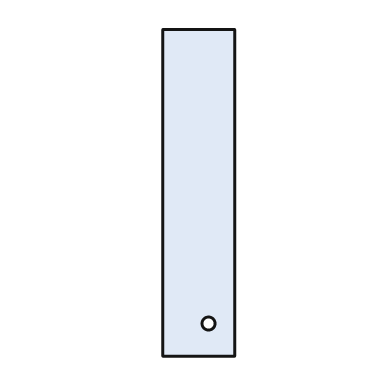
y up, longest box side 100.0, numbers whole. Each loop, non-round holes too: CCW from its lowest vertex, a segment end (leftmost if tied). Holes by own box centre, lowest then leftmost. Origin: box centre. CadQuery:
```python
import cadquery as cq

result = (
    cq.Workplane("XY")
    .moveTo(-11.0, -50.0)
    .lineTo(11.0, -50.0)
    .lineTo(11.0, 50.0)
    .lineTo(-11.0, 50.0)
    .close()
    .moveTo(3.0, -40.0)
    .circle(2.0)
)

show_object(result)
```